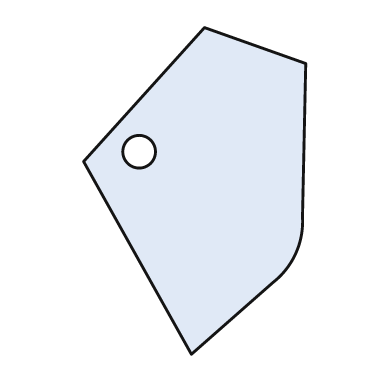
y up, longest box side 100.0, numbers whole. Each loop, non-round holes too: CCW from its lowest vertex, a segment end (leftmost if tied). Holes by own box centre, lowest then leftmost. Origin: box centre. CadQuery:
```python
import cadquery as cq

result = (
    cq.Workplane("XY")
    .moveTo(-1.0, -50.0)
    .lineTo(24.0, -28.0)
    .threePointArc((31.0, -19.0), (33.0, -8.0))
    .lineTo(34.0, 39.0)
    .lineTo(3.0, 50.0)
    .lineTo(-34.0, 9.0)
    .close()
    .moveTo(-17.0, 12.0)
    .circle(5.0)
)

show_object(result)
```